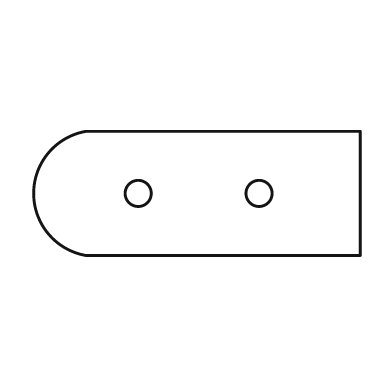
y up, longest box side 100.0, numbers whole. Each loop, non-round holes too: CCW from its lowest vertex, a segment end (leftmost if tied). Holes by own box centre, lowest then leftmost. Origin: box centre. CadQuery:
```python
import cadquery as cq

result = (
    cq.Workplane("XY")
    .moveTo(-34.0, -19.0)
    .lineTo(50.0, -19.0)
    .lineTo(50.0, 19.0)
    .lineTo(-34.0, 19.0)
    .threePointArc((-50.0, 0.0), (-34.0, -19.0))
    .close()
    .moveTo(-18.0, 0.0)
    .circle(4.0)
    .moveTo(19.0, 0.0)
    .circle(4.0)
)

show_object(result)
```